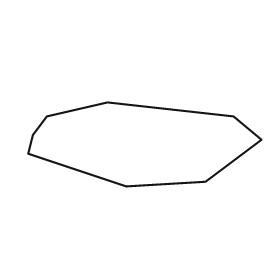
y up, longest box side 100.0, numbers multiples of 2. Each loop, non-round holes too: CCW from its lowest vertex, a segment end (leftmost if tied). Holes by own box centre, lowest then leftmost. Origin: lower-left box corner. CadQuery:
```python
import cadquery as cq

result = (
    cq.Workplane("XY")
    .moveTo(42.0, 0.0)
    .lineTo(76.0, 2.0)
    .lineTo(100.0, 20.0)
    .lineTo(88.0, 30.0)
    .lineTo(34.0, 36.0)
    .lineTo(8.0, 30.0)
    .lineTo(2.0, 22.0)
    .lineTo(0.0, 14.0)
    .close()
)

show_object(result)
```